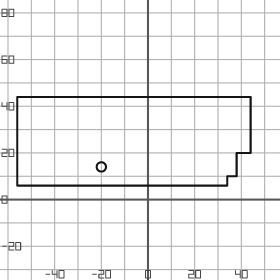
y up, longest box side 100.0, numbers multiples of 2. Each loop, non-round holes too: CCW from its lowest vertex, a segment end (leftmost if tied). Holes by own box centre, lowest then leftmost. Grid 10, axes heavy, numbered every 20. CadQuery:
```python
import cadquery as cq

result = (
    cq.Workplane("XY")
    .moveTo(-56.0, 6.0)
    .lineTo(34.0, 6.0)
    .lineTo(34.0, 10.0)
    .lineTo(38.0, 10.0)
    .lineTo(38.0, 20.0)
    .lineTo(44.0, 20.0)
    .lineTo(44.0, 44.0)
    .lineTo(-56.0, 44.0)
    .close()
    .moveTo(-20.0, 14.0)
    .circle(2.0)
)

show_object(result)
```